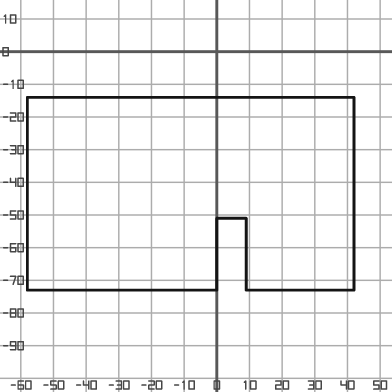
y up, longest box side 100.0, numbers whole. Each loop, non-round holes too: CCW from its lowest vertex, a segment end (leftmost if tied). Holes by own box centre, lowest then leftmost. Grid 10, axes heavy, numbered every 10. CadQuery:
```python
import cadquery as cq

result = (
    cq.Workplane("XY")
    .moveTo(-58.0, -73.0)
    .lineTo(0.0, -73.0)
    .lineTo(0.0, -51.0)
    .lineTo(9.0, -51.0)
    .lineTo(9.0, -73.0)
    .lineTo(42.0, -73.0)
    .lineTo(42.0, -14.0)
    .lineTo(-58.0, -14.0)
    .close()
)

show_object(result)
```